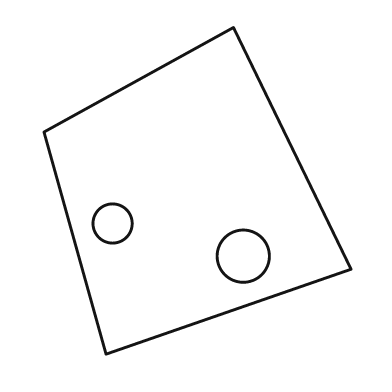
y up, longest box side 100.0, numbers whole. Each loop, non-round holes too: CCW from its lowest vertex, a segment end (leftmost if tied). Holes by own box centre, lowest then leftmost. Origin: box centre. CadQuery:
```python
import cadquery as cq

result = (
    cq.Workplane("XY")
    .moveTo(-28.0, -50.0)
    .lineTo(47.0, -24.0)
    .lineTo(11.0, 50.0)
    .lineTo(-47.0, 18.0)
    .close()
    .moveTo(14.0, -20.0)
    .circle(8.0)
    .moveTo(-26.0, -10.0)
    .circle(6.0)
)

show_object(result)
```